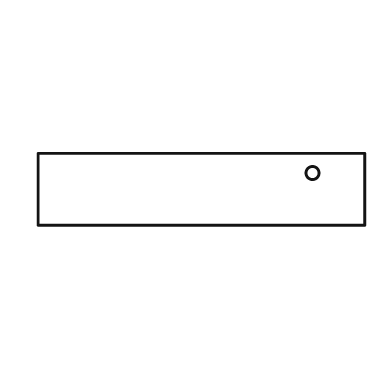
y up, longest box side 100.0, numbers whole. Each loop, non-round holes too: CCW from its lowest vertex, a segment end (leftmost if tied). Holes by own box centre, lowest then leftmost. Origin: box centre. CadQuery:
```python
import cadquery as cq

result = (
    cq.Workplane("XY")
    .moveTo(-50.0, -11.0)
    .lineTo(50.0, -11.0)
    .lineTo(50.0, 11.0)
    .lineTo(-50.0, 11.0)
    .close()
    .moveTo(34.0, 5.0)
    .circle(2.0)
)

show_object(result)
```